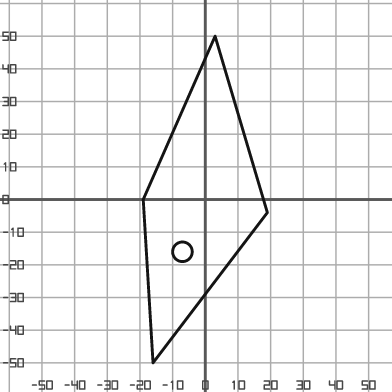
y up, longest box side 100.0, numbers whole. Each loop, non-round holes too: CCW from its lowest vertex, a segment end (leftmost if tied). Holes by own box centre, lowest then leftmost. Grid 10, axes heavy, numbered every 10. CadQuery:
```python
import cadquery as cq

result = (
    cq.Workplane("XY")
    .moveTo(-16.0, -50.0)
    .lineTo(19.0, -4.0)
    .lineTo(3.0, 50.0)
    .lineTo(-19.0, 0.0)
    .close()
    .moveTo(-7.0, -16.0)
    .circle(3.0)
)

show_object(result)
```